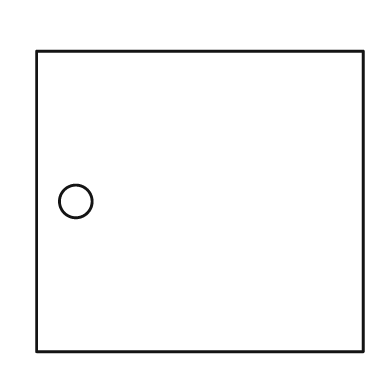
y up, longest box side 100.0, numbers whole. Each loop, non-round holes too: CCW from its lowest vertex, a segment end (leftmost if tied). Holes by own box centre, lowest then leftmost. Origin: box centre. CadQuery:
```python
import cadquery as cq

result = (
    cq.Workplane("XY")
    .moveTo(-50.0, -46.0)
    .lineTo(50.0, -46.0)
    .lineTo(50.0, 46.0)
    .lineTo(-50.0, 46.0)
    .close()
    .moveTo(-38.0, 0.0)
    .circle(5.0)
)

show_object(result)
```